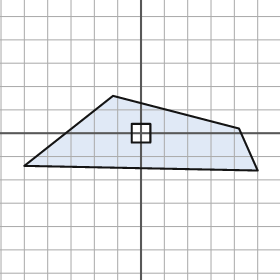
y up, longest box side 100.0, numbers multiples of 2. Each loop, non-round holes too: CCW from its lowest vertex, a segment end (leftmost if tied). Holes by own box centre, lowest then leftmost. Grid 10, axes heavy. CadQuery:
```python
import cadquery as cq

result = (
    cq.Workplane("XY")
    .moveTo(50.0, -16.0)
    .lineTo(42.0, 2.0)
    .lineTo(-12.0, 16.0)
    .lineTo(-50.0, -14.0)
    .close()
    .moveTo(-4.0, -4.0)
    .lineTo(4.0, -4.0)
    .lineTo(4.0, 4.0)
    .lineTo(-4.0, 4.0)
    .close()
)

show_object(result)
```